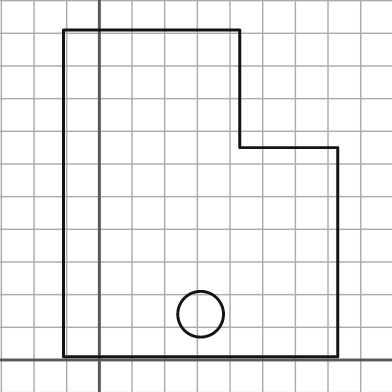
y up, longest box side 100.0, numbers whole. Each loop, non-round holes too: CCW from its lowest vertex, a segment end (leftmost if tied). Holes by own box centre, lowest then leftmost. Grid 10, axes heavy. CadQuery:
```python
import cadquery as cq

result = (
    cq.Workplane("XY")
    .moveTo(-11.0, 1.0)
    .lineTo(73.0, 1.0)
    .lineTo(73.0, 65.0)
    .lineTo(43.0, 65.0)
    .lineTo(43.0, 101.0)
    .lineTo(-11.0, 101.0)
    .close()
    .moveTo(31.0, 14.0)
    .circle(7.0)
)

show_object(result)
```